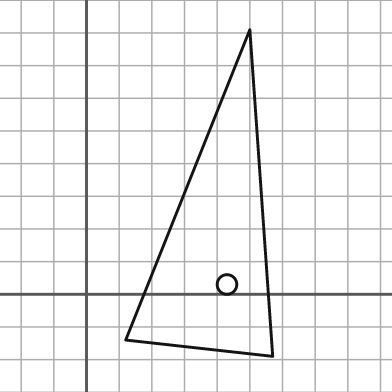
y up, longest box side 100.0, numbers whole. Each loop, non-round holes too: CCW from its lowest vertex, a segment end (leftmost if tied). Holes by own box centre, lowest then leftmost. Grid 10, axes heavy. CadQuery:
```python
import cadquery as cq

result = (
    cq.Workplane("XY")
    .moveTo(57.0, -19.0)
    .lineTo(50.0, 81.0)
    .lineTo(12.0, -14.0)
    .close()
    .moveTo(43.0, 3.0)
    .circle(3.0)
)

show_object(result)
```